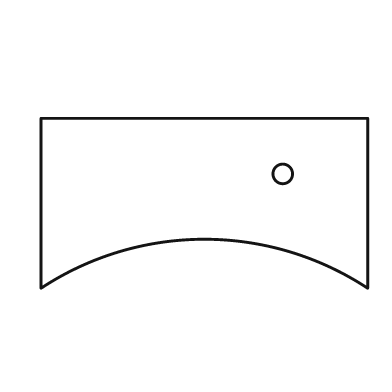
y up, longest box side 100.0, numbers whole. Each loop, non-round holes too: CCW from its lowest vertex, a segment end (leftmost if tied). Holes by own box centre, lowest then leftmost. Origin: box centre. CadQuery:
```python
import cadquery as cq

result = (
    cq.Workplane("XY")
    .moveTo(-50.0, -26.0)
    .threePointArc((0.0, -11.0), (50.0, -26.0))
    .lineTo(50.0, 26.0)
    .lineTo(-50.0, 26.0)
    .close()
    .moveTo(24.0, 9.0)
    .circle(3.0)
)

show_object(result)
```